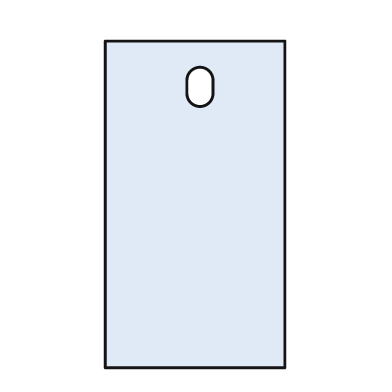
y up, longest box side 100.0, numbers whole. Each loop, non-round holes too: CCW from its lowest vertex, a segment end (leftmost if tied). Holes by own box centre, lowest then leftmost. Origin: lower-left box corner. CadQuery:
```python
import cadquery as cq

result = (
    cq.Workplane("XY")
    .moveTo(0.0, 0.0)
    .lineTo(55.0, 0.0)
    .lineTo(55.0, 100.0)
    .lineTo(0.0, 100.0)
    .close()
    .moveTo(25.0, 84.0)
    .threePointArc((29.0, 80.0), (33.0, 84.0))
    .lineTo(33.0, 88.0)
    .threePointArc((29.0, 92.0), (25.0, 88.0))
    .close()
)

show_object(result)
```